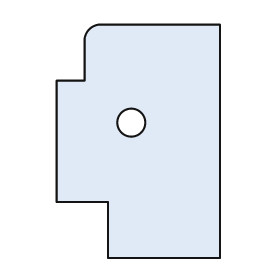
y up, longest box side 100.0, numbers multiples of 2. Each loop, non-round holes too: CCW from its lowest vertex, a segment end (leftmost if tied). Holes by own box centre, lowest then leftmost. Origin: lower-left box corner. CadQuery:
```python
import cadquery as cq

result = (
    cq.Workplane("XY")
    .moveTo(22.0, 0.0)
    .lineTo(70.0, 0.0)
    .lineTo(70.0, 100.0)
    .lineTo(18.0, 100.0)
    .threePointArc((14.0, 98.0), (12.0, 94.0))
    .lineTo(12.0, 76.0)
    .lineTo(0.0, 76.0)
    .lineTo(0.0, 24.0)
    .lineTo(22.0, 24.0)
    .close()
    .moveTo(32.0, 58.0)
    .circle(6.0)
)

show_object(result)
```